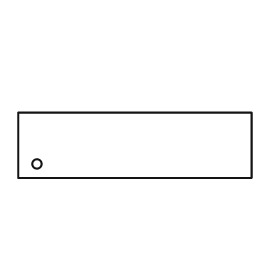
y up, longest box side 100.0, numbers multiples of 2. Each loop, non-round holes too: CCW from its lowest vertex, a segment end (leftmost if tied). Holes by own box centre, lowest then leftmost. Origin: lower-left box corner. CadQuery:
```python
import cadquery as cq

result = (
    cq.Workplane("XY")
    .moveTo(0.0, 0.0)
    .lineTo(100.0, 0.0)
    .lineTo(100.0, 28.0)
    .lineTo(0.0, 28.0)
    .close()
    .moveTo(8.0, 6.0)
    .circle(2.0)
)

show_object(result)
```